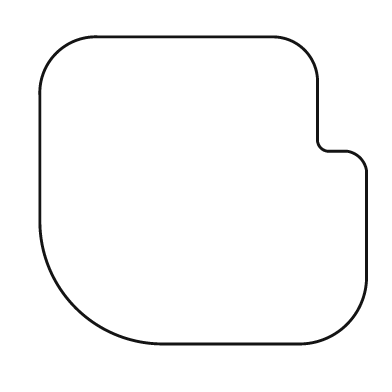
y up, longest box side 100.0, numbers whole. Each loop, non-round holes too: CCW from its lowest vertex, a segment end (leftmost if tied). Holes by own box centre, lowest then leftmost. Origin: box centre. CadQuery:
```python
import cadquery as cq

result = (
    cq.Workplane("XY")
    .moveTo(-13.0, -47.0)
    .lineTo(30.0, -47.0)
    .threePointArc((44.0, -41.0), (50.0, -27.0))
    .lineTo(50.0, 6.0)
    .threePointArc((48.0, 10.0), (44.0, 12.0))
    .lineTo(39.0, 12.0)
    .threePointArc((36.0, 13.0), (35.0, 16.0))
    .lineTo(35.0, 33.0)
    .threePointArc((31.0, 43.0), (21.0, 47.0))
    .lineTo(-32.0, 47.0)
    .threePointArc((-45.0, 42.0), (-50.0, 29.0))
    .lineTo(-50.0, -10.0)
    .threePointArc((-39.0, -36.0), (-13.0, -47.0))
    .close()
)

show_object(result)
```